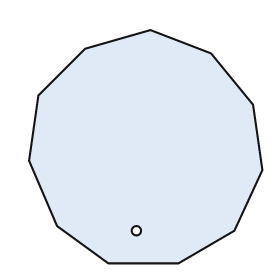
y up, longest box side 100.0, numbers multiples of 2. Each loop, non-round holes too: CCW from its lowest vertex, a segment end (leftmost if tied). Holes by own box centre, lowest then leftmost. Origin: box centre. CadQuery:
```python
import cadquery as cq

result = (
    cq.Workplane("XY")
    .moveTo(-16.0, -50.0)
    .lineTo(14.0, -50.0)
    .lineTo(38.0, -36.0)
    .lineTo(50.0, -10.0)
    .lineTo(46.0, 18.0)
    .lineTo(28.0, 40.0)
    .lineTo(2.0, 50.0)
    .lineTo(-26.0, 42.0)
    .lineTo(-46.0, 22.0)
    .lineTo(-50.0, -6.0)
    .lineTo(-38.0, -34.0)
    .close()
    .moveTo(-4.0, -36.0)
    .circle(2.0)
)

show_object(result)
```